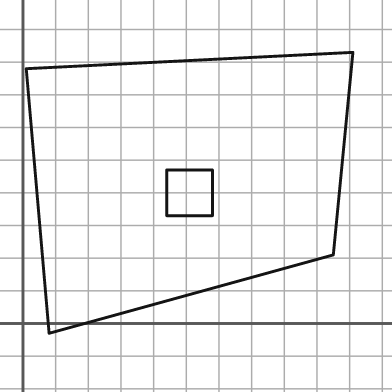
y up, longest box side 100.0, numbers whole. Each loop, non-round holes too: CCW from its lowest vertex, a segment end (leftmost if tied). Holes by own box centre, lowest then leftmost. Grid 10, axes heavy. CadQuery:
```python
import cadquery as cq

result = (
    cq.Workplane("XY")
    .moveTo(8.0, -3.0)
    .lineTo(95.0, 21.0)
    .lineTo(101.0, 83.0)
    .lineTo(1.0, 78.0)
    .close()
    .moveTo(44.0, 33.0)
    .lineTo(58.0, 33.0)
    .lineTo(58.0, 47.0)
    .lineTo(44.0, 47.0)
    .close()
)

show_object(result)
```